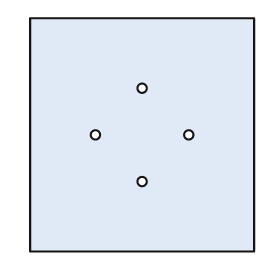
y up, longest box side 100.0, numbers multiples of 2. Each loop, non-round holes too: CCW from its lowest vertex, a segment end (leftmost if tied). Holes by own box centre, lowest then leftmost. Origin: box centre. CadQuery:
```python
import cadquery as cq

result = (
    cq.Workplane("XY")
    .moveTo(-48.0, -50.0)
    .lineTo(48.0, -50.0)
    .lineTo(48.0, 50.0)
    .lineTo(-48.0, 50.0)
    .close()
    .moveTo(0.0, -20.0)
    .circle(2.0)
    .moveTo(-20.0, 0.0)
    .circle(2.0)
    .moveTo(20.0, 0.0)
    .circle(2.0)
    .moveTo(0.0, 20.0)
    .circle(2.0)
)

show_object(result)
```